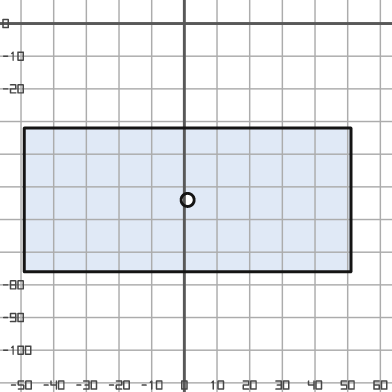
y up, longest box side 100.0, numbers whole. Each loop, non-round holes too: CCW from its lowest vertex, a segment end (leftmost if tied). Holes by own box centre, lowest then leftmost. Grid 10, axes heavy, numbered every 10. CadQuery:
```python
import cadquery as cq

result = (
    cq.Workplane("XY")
    .moveTo(-49.0, -76.0)
    .lineTo(51.0, -76.0)
    .lineTo(51.0, -32.0)
    .lineTo(-49.0, -32.0)
    .close()
    .moveTo(1.0, -54.0)
    .circle(2.0)
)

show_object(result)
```